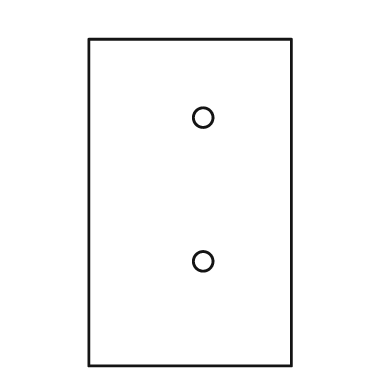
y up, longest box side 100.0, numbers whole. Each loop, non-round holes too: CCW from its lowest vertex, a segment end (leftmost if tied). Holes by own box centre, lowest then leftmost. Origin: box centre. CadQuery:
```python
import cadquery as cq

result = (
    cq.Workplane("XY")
    .moveTo(-31.0, -50.0)
    .lineTo(31.0, -50.0)
    .lineTo(31.0, 50.0)
    .lineTo(-31.0, 50.0)
    .close()
    .moveTo(4.0, -18.0)
    .circle(3.0)
    .moveTo(4.0, 26.0)
    .circle(3.0)
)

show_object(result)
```